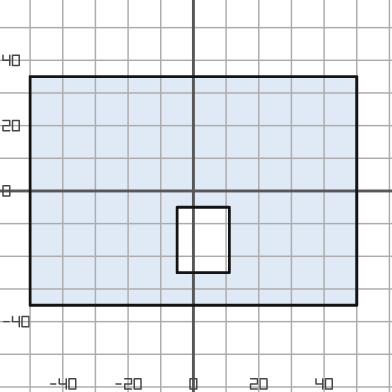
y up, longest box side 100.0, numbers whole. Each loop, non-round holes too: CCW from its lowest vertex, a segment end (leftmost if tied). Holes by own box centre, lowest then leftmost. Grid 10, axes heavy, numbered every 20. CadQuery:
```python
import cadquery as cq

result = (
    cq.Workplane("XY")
    .moveTo(-50.0, -35.0)
    .lineTo(50.0, -35.0)
    .lineTo(50.0, 35.0)
    .lineTo(-50.0, 35.0)
    .close()
    .moveTo(-5.0, -25.0)
    .lineTo(11.0, -25.0)
    .lineTo(11.0, -5.0)
    .lineTo(-5.0, -5.0)
    .close()
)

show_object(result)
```